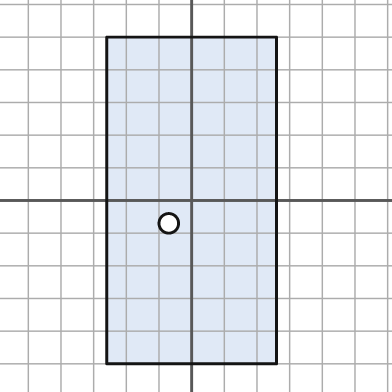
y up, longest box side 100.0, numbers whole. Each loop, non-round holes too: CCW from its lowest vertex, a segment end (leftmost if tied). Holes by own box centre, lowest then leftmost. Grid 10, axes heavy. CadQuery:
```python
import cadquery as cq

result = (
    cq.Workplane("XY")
    .moveTo(-26.0, -50.0)
    .lineTo(26.0, -50.0)
    .lineTo(26.0, 50.0)
    .lineTo(-26.0, 50.0)
    .close()
    .moveTo(-7.0, -7.0)
    .circle(3.0)
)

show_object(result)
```